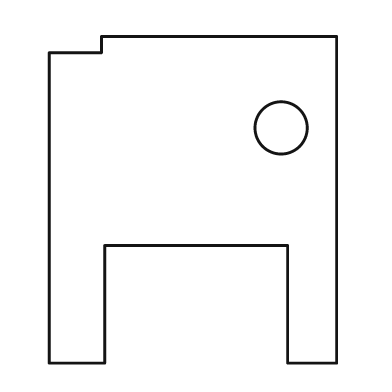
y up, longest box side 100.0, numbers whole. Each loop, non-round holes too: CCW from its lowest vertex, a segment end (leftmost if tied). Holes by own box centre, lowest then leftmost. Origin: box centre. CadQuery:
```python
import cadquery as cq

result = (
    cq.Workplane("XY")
    .moveTo(-44.0, -50.0)
    .lineTo(-27.0, -50.0)
    .lineTo(-27.0, -14.0)
    .lineTo(29.0, -14.0)
    .lineTo(29.0, -50.0)
    .lineTo(44.0, -50.0)
    .lineTo(44.0, 50.0)
    .lineTo(-28.0, 50.0)
    .lineTo(-28.0, 45.0)
    .lineTo(-44.0, 45.0)
    .close()
    .moveTo(27.0, 22.0)
    .circle(8.0)
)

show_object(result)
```